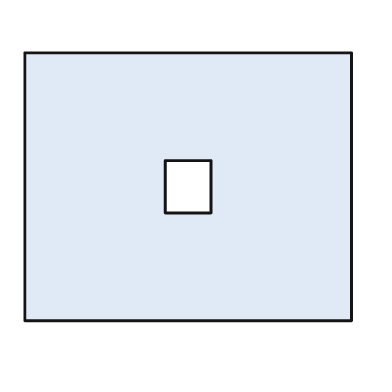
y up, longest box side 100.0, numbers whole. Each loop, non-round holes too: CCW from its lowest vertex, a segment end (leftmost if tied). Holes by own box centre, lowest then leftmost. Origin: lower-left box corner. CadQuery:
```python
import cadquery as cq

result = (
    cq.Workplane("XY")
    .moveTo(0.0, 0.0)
    .lineTo(100.0, 0.0)
    .lineTo(100.0, 82.0)
    .lineTo(0.0, 82.0)
    .close()
    .moveTo(43.0, 33.0)
    .lineTo(57.0, 33.0)
    .lineTo(57.0, 49.0)
    .lineTo(43.0, 49.0)
    .close()
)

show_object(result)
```